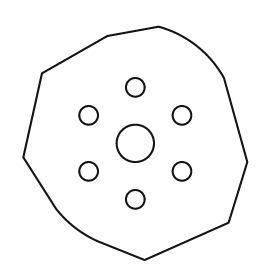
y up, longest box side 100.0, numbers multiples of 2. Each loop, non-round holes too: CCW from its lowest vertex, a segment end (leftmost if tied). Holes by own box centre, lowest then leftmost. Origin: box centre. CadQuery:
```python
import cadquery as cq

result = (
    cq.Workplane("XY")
    .moveTo(4.0, -50.0)
    .lineTo(40.0, -34.0)
    .lineTo(48.0, -8.0)
    .lineTo(38.0, 28.0)
    .threePointArc((26.0, 42.0), (10.0, 50.0))
    .lineTo(-12.0, 46.0)
    .lineTo(-40.0, 30.0)
    .lineTo(-48.0, -6.0)
    .lineTo(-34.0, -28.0)
    .threePointArc((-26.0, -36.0), (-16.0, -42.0))
    .close()
    .moveTo(0.0, -24.0)
    .circle(4.0)
    .moveTo(-20.0, -12.0)
    .circle(4.0)
    .moveTo(20.0, -12.0)
    .circle(4.0)
    .moveTo(0.0, 0.0)
    .circle(8.0)
    .moveTo(-20.0, 12.0)
    .circle(4.0)
    .moveTo(20.0, 12.0)
    .circle(4.0)
    .moveTo(0.0, 24.0)
    .circle(4.0)
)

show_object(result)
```